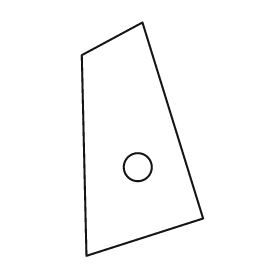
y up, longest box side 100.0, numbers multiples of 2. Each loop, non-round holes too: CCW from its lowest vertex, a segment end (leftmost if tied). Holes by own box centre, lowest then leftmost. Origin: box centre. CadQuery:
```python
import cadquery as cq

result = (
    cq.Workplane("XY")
    .moveTo(-24.0, -50.0)
    .lineTo(26.0, -34.0)
    .lineTo(0.0, 50.0)
    .lineTo(-26.0, 36.0)
    .close()
    .moveTo(-2.0, -12.0)
    .circle(6.0)
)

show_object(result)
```